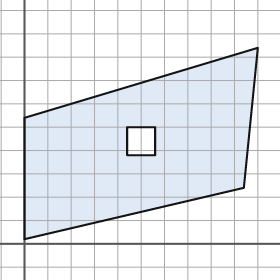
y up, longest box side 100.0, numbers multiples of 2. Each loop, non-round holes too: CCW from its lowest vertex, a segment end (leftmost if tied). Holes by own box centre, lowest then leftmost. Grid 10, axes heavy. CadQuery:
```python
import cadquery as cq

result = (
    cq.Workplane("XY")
    .moveTo(0.0, 2.0)
    .lineTo(94.0, 24.0)
    .lineTo(100.0, 84.0)
    .lineTo(0.0, 54.0)
    .close()
    .moveTo(44.0, 38.0)
    .lineTo(56.0, 38.0)
    .lineTo(56.0, 50.0)
    .lineTo(44.0, 50.0)
    .close()
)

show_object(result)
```